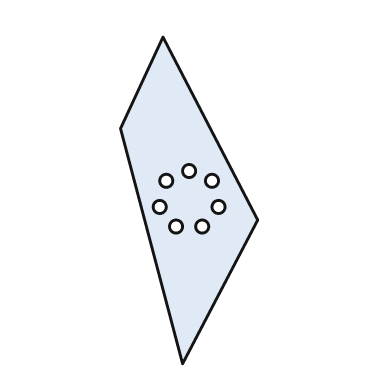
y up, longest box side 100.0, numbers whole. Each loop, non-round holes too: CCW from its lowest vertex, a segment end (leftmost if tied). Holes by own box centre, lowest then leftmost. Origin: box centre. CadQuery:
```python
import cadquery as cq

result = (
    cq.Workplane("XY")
    .moveTo(-2.0, -50.0)
    .lineTo(21.0, -6.0)
    .lineTo(-8.0, 50.0)
    .lineTo(-21.0, 22.0)
    .close()
    .moveTo(-4.0, -8.0)
    .circle(2.0)
    .moveTo(4.0, -8.0)
    .circle(2.0)
    .moveTo(-9.0, -2.0)
    .circle(2.0)
    .moveTo(9.0, -2.0)
    .circle(2.0)
    .moveTo(-7.0, 6.0)
    .circle(2.0)
    .moveTo(7.0, 6.0)
    .circle(2.0)
    .moveTo(0.0, 9.0)
    .circle(2.0)
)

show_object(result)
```